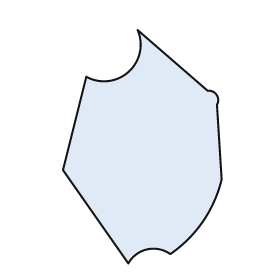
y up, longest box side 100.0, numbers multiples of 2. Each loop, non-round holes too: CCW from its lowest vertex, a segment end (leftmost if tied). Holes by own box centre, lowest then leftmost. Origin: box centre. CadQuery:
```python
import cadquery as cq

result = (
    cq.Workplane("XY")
    .moveTo(-6.0, -50.0)
    .threePointArc((2.0, -44.0), (12.0, -46.0))
    .threePointArc((26.0, -32.0), (34.0, -14.0))
    .lineTo(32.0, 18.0)
    .threePointArc((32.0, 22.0), (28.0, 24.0))
    .lineTo(-2.0, 50.0)
    .threePointArc((-6.0, 32.0), (-24.0, 30.0))
    .lineTo(-34.0, -10.0)
    .close()
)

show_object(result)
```